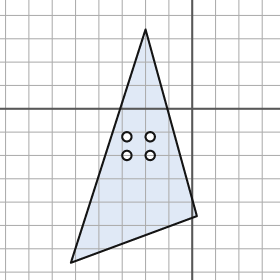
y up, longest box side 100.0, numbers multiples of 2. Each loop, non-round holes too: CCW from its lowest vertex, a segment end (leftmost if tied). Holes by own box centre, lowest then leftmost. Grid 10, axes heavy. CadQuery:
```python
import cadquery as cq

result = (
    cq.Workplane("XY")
    .moveTo(-52.0, -66.0)
    .lineTo(2.0, -46.0)
    .lineTo(-20.0, 34.0)
    .close()
    .moveTo(-28.0, -20.0)
    .circle(2.0)
    .moveTo(-18.0, -20.0)
    .circle(2.0)
    .moveTo(-28.0, -12.0)
    .circle(2.0)
    .moveTo(-18.0, -12.0)
    .circle(2.0)
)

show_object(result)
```